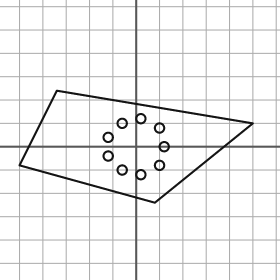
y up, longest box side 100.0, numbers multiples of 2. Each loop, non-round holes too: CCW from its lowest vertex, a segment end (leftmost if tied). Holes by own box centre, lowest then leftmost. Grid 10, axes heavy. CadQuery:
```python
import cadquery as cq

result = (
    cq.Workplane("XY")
    .moveTo(8.0, -24.0)
    .lineTo(50.0, 10.0)
    .lineTo(-34.0, 24.0)
    .lineTo(-50.0, -8.0)
    .close()
    .moveTo(2.0, -12.0)
    .circle(2.0)
    .moveTo(-6.0, -10.0)
    .circle(2.0)
    .moveTo(10.0, -8.0)
    .circle(2.0)
    .moveTo(-12.0, -4.0)
    .circle(2.0)
    .moveTo(12.0, 0.0)
    .circle(2.0)
    .moveTo(-12.0, 4.0)
    .circle(2.0)
    .moveTo(10.0, 8.0)
    .circle(2.0)
    .moveTo(-6.0, 10.0)
    .circle(2.0)
    .moveTo(2.0, 12.0)
    .circle(2.0)
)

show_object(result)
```